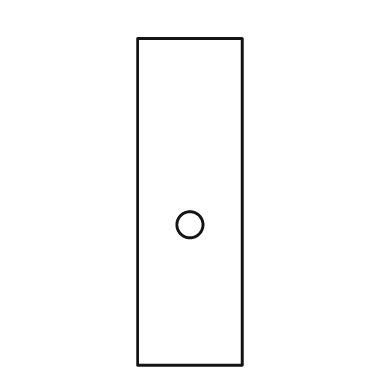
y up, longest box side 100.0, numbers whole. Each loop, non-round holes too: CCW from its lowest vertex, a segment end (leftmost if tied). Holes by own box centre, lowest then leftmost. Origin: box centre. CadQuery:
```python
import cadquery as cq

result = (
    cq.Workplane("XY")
    .moveTo(-16.0, -50.0)
    .lineTo(16.0, -50.0)
    .lineTo(16.0, 50.0)
    .lineTo(-16.0, 50.0)
    .close()
    .moveTo(0.0, -7.0)
    .circle(4.0)
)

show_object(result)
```